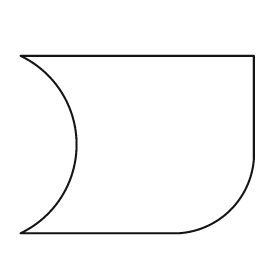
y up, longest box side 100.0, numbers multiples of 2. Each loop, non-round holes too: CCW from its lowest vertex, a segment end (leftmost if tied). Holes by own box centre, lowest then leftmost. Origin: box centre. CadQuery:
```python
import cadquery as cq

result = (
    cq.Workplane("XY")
    .moveTo(-50.0, -38.0)
    .lineTo(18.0, -38.0)
    .threePointArc((40.0, -28.0), (50.0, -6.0))
    .lineTo(50.0, 38.0)
    .lineTo(-50.0, 38.0)
    .threePointArc((-26.0, 0.0), (-50.0, -38.0))
    .close()
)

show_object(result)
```